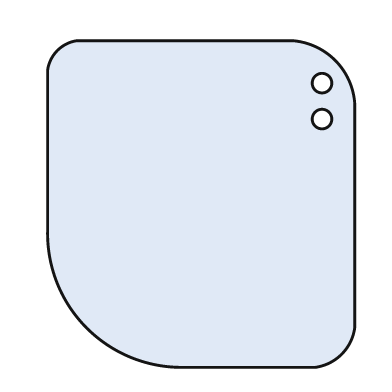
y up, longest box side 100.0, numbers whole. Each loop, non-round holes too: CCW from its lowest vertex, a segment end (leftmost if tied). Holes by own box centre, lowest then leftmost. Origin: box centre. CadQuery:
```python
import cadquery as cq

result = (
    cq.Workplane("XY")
    .moveTo(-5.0, -50.0)
    .lineTo(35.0, -50.0)
    .threePointArc((43.0, -46.0), (47.0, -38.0))
    .lineTo(47.0, 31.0)
    .threePointArc((41.0, 44.0), (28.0, 50.0))
    .lineTo(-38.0, 50.0)
    .threePointArc((-44.0, 47.0), (-47.0, 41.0))
    .lineTo(-47.0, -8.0)
    .threePointArc((-35.0, -38.0), (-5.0, -50.0))
    .close()
    .moveTo(37.0, 26.0)
    .circle(3.0)
    .moveTo(37.0, 37.0)
    .circle(3.0)
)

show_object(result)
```